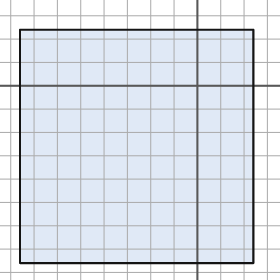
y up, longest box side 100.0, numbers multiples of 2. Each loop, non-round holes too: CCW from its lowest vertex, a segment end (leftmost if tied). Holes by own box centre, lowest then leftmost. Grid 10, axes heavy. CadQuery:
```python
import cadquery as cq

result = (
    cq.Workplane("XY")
    .moveTo(-76.0, -76.0)
    .lineTo(24.0, -76.0)
    .lineTo(24.0, 24.0)
    .lineTo(-76.0, 24.0)
    .close()
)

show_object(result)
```